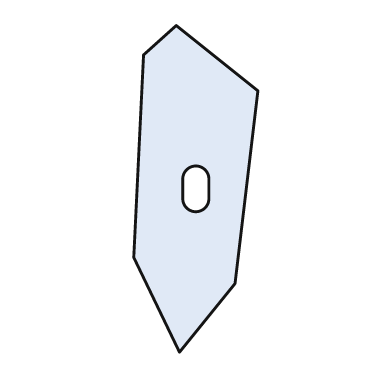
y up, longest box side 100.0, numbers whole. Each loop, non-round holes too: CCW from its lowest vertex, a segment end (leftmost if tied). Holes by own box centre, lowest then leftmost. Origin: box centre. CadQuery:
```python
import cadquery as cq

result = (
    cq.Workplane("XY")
    .moveTo(-5.0, -50.0)
    .lineTo(12.0, -29.0)
    .lineTo(19.0, 30.0)
    .lineTo(-6.0, 50.0)
    .lineTo(-16.0, 41.0)
    .lineTo(-19.0, -21.0)
    .close()
    .moveTo(-4.0, -3.0)
    .threePointArc((0.0, -7.0), (4.0, -3.0))
    .lineTo(4.0, 3.0)
    .threePointArc((0.0, 7.0), (-4.0, 3.0))
    .close()
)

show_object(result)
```